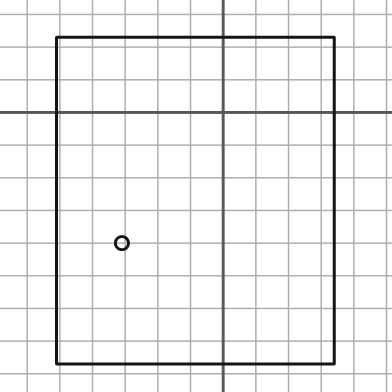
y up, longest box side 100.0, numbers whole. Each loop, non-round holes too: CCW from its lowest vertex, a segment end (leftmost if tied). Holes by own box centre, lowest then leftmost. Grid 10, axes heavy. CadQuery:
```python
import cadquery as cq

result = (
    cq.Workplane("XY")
    .moveTo(-51.0, -77.0)
    .lineTo(34.0, -77.0)
    .lineTo(34.0, 23.0)
    .lineTo(-51.0, 23.0)
    .close()
    .moveTo(-31.0, -40.0)
    .circle(2.0)
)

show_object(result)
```